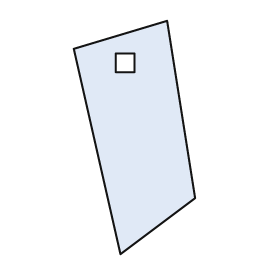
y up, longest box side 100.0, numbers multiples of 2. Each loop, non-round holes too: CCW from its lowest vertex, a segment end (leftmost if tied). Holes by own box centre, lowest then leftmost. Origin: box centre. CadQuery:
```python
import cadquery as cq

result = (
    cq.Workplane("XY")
    .moveTo(-6.0, -50.0)
    .lineTo(26.0, -26.0)
    .lineTo(14.0, 50.0)
    .lineTo(-26.0, 38.0)
    .close()
    .moveTo(-8.0, 28.0)
    .lineTo(0.0, 28.0)
    .lineTo(0.0, 36.0)
    .lineTo(-8.0, 36.0)
    .close()
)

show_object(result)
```